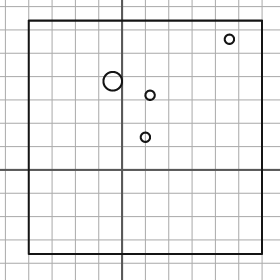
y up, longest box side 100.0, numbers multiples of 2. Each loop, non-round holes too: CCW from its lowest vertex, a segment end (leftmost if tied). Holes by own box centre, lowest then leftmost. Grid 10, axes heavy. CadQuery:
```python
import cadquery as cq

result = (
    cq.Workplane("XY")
    .moveTo(-40.0, -36.0)
    .lineTo(60.0, -36.0)
    .lineTo(60.0, 64.0)
    .lineTo(-40.0, 64.0)
    .close()
    .moveTo(10.0, 14.0)
    .circle(2.0)
    .moveTo(12.0, 32.0)
    .circle(2.0)
    .moveTo(-4.0, 38.0)
    .circle(4.0)
    .moveTo(46.0, 56.0)
    .circle(2.0)
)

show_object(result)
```